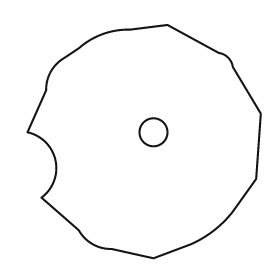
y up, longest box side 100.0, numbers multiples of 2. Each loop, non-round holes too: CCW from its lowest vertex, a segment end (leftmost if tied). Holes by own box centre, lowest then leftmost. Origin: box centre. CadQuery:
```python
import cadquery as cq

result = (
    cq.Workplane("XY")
    .moveTo(4.0, -50.0)
    .lineTo(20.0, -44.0)
    .threePointArc((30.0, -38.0), (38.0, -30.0))
    .lineTo(48.0, -16.0)
    .lineTo(50.0, 12.0)
    .lineTo(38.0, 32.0)
    .threePointArc((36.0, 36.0), (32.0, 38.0))
    .lineTo(10.0, 50.0)
    .lineTo(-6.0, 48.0)
    .threePointArc((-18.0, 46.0), (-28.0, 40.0))
    .lineTo(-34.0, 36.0)
    .threePointArc((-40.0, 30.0), (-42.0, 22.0))
    .lineTo(-50.0, 4.0)
    .threePointArc((-38.0, -8.0), (-44.0, -24.0))
    .lineTo(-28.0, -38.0)
    .threePointArc((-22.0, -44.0), (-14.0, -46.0))
    .close()
    .moveTo(4.0, 4.0)
    .circle(6.0)
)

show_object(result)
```